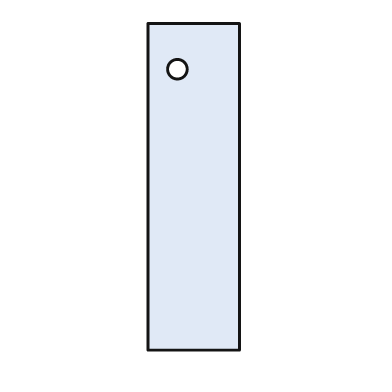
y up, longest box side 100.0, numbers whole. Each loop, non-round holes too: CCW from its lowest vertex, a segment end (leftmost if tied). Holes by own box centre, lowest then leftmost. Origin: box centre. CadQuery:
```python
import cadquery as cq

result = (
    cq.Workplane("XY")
    .moveTo(-14.0, -50.0)
    .lineTo(14.0, -50.0)
    .lineTo(14.0, 50.0)
    .lineTo(-14.0, 50.0)
    .close()
    .moveTo(-5.0, 36.0)
    .circle(3.0)
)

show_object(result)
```